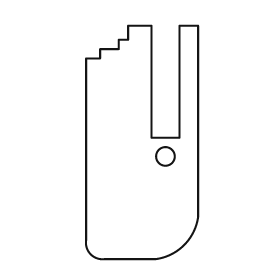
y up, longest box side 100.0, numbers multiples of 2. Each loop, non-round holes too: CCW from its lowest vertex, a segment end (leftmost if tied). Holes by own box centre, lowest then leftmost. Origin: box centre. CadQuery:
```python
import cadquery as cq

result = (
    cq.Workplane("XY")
    .moveTo(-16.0, -50.0)
    .lineTo(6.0, -50.0)
    .threePointArc((18.0, -44.0), (24.0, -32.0))
    .lineTo(24.0, 50.0)
    .lineTo(16.0, 50.0)
    .lineTo(16.0, 2.0)
    .lineTo(4.0, 2.0)
    .lineTo(4.0, 50.0)
    .lineTo(-6.0, 50.0)
    .lineTo(-6.0, 44.0)
    .lineTo(-10.0, 44.0)
    .lineTo(-10.0, 40.0)
    .lineTo(-18.0, 40.0)
    .lineTo(-18.0, 36.0)
    .lineTo(-24.0, 36.0)
    .lineTo(-24.0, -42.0)
    .threePointArc((-22.0, -48.0), (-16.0, -50.0))
    .close()
    .moveTo(10.0, -6.0)
    .circle(4.0)
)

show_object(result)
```